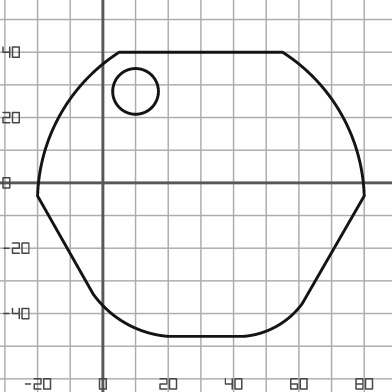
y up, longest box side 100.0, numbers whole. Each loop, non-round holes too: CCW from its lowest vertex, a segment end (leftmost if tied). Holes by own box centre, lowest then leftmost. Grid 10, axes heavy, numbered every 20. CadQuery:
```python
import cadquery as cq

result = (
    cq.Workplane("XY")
    .moveTo(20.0, -47.0)
    .lineTo(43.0, -47.0)
    .threePointArc((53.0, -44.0), (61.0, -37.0))
    .lineTo(80.0, -4.0)
    .threePointArc((73.0, 21.0), (55.0, 40.0))
    .lineTo(5.0, 40.0)
    .threePointArc((-13.0, 21.0), (-20.0, -4.0))
    .lineTo(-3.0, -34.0)
    .threePointArc((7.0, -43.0), (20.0, -47.0))
    .close()
    .moveTo(10.0, 28.0)
    .circle(7.0)
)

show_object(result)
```